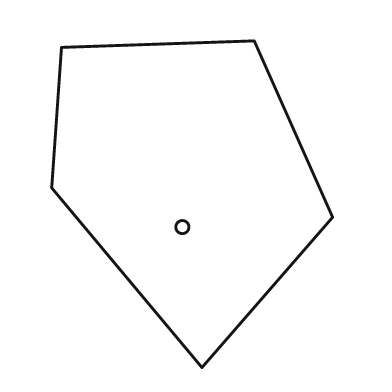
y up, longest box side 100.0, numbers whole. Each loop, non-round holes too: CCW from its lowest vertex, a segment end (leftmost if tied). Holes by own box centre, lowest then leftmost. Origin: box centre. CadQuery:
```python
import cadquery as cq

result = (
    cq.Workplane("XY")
    .moveTo(3.0, -50.0)
    .lineTo(43.0, -4.0)
    .lineTo(19.0, 50.0)
    .lineTo(-40.0, 48.0)
    .lineTo(-43.0, 5.0)
    .close()
    .moveTo(-3.0, -7.0)
    .circle(2.0)
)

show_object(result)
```